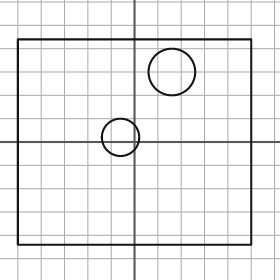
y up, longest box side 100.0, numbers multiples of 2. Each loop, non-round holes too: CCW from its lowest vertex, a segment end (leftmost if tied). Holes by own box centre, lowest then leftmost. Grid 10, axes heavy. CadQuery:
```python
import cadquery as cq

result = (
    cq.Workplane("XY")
    .moveTo(-50.0, -44.0)
    .lineTo(50.0, -44.0)
    .lineTo(50.0, 44.0)
    .lineTo(-50.0, 44.0)
    .close()
    .moveTo(-6.0, 2.0)
    .circle(8.0)
    .moveTo(16.0, 30.0)
    .circle(10.0)
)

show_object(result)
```